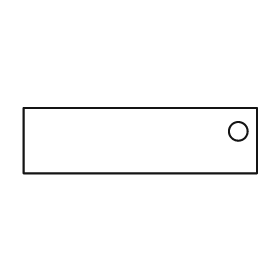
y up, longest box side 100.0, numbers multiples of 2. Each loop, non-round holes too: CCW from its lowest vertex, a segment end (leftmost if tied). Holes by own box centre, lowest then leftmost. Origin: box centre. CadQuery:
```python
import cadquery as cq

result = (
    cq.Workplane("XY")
    .moveTo(-50.0, -14.0)
    .lineTo(50.0, -14.0)
    .lineTo(50.0, 14.0)
    .lineTo(-50.0, 14.0)
    .close()
    .moveTo(42.0, 4.0)
    .circle(4.0)
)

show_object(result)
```